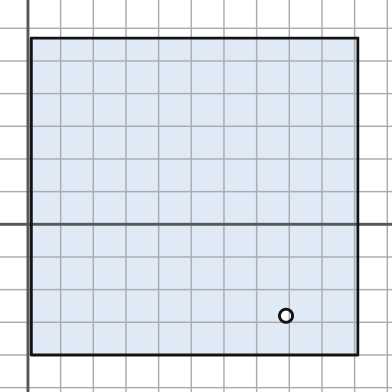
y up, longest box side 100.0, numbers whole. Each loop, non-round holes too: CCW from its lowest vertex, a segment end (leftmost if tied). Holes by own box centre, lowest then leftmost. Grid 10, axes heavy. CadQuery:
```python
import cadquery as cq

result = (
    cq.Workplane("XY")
    .moveTo(1.0, -40.0)
    .lineTo(101.0, -40.0)
    .lineTo(101.0, 57.0)
    .lineTo(1.0, 57.0)
    .close()
    .moveTo(79.0, -28.0)
    .circle(2.0)
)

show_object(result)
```